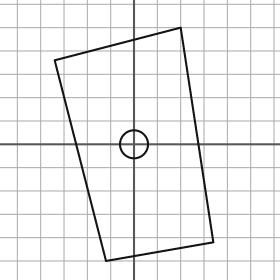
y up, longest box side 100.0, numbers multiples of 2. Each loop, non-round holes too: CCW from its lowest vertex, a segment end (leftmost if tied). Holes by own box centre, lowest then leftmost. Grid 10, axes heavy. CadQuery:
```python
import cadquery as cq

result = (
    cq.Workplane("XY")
    .moveTo(-12.0, -50.0)
    .lineTo(34.0, -42.0)
    .lineTo(20.0, 50.0)
    .lineTo(-34.0, 36.0)
    .close()
    .moveTo(0.0, 0.0)
    .circle(6.0)
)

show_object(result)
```